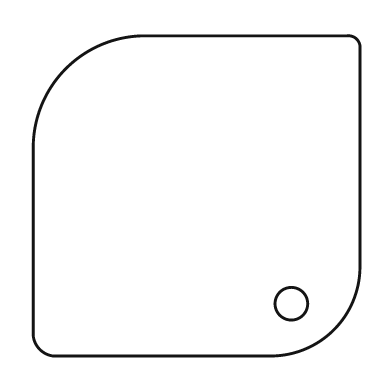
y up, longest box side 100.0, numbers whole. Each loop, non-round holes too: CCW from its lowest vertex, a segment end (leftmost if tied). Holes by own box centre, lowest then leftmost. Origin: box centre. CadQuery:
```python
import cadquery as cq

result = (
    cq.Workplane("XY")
    .moveTo(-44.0, -49.0)
    .lineTo(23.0, -49.0)
    .threePointArc((42.0, -41.0), (50.0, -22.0))
    .lineTo(50.0, 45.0)
    .threePointArc((49.0, 48.0), (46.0, 49.0))
    .lineTo(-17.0, 49.0)
    .threePointArc((-40.0, 39.0), (-50.0, 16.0))
    .lineTo(-50.0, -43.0)
    .threePointArc((-48.0, -47.0), (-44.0, -49.0))
    .close()
    .moveTo(29.0, -33.0)
    .circle(5.0)
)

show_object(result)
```